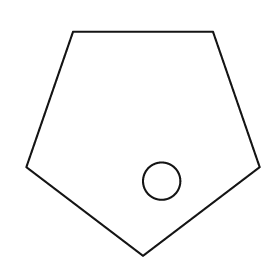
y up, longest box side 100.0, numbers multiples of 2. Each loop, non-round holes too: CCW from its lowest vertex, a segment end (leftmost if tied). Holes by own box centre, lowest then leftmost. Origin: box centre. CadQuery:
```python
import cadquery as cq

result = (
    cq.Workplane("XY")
    .moveTo(0.0, -48.0)
    .lineTo(50.0, -10.0)
    .lineTo(30.0, 48.0)
    .lineTo(-30.0, 48.0)
    .lineTo(-50.0, -10.0)
    .close()
    .moveTo(8.0, -16.0)
    .circle(8.0)
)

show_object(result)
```